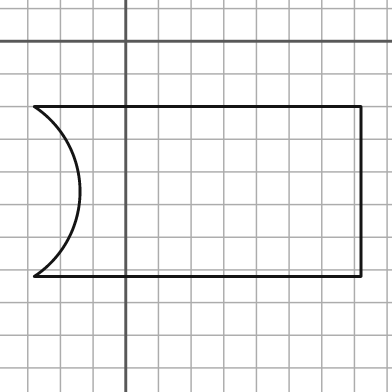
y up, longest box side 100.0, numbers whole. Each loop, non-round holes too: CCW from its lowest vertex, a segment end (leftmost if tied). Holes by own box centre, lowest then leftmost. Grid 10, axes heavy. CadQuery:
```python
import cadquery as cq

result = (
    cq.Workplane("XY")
    .moveTo(-28.0, -72.0)
    .lineTo(72.0, -72.0)
    .lineTo(72.0, -20.0)
    .lineTo(-28.0, -20.0)
    .threePointArc((-14.0, -46.0), (-28.0, -72.0))
    .close()
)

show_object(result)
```